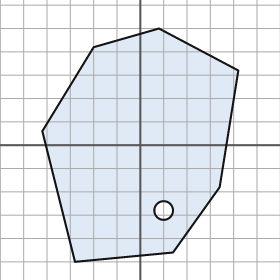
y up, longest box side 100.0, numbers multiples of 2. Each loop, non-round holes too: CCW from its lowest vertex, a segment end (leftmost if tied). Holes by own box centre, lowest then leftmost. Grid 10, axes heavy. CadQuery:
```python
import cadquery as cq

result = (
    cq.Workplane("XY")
    .moveTo(-28.0, -50.0)
    .lineTo(14.0, -46.0)
    .lineTo(34.0, -18.0)
    .lineTo(42.0, 32.0)
    .lineTo(8.0, 50.0)
    .lineTo(-20.0, 42.0)
    .lineTo(-42.0, 6.0)
    .close()
    .moveTo(10.0, -28.0)
    .circle(4.0)
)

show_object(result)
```